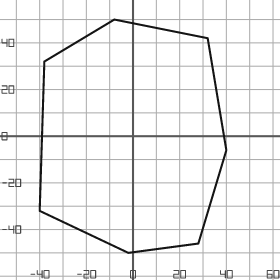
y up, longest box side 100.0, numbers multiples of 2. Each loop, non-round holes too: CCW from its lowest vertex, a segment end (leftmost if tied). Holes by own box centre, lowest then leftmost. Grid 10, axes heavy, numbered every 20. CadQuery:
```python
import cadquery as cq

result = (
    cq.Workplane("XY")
    .moveTo(-2.0, -50.0)
    .lineTo(28.0, -46.0)
    .lineTo(40.0, -6.0)
    .lineTo(32.0, 42.0)
    .lineTo(-8.0, 50.0)
    .lineTo(-38.0, 32.0)
    .lineTo(-40.0, -32.0)
    .close()
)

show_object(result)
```